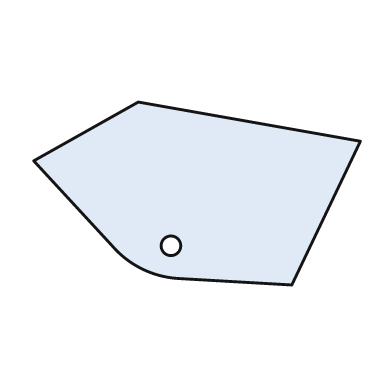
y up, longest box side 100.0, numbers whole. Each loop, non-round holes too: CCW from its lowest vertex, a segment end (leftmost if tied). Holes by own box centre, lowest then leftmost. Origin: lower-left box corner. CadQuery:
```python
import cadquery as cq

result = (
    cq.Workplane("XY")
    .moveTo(79.0, 0.0)
    .lineTo(100.0, 44.0)
    .lineTo(32.0, 56.0)
    .lineTo(0.0, 38.0)
    .lineTo(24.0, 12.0)
    .threePointArc((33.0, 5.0), (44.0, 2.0))
    .close()
    .moveTo(42.0, 12.0)
    .circle(3.0)
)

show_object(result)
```